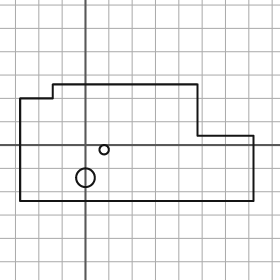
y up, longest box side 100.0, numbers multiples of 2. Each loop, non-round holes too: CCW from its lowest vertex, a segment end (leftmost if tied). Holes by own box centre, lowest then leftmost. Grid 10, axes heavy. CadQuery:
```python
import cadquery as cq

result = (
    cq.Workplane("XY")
    .moveTo(-28.0, -24.0)
    .lineTo(72.0, -24.0)
    .lineTo(72.0, 4.0)
    .lineTo(48.0, 4.0)
    .lineTo(48.0, 26.0)
    .lineTo(-14.0, 26.0)
    .lineTo(-14.0, 20.0)
    .lineTo(-28.0, 20.0)
    .close()
    .moveTo(0.0, -14.0)
    .circle(4.0)
    .moveTo(8.0, -2.0)
    .circle(2.0)
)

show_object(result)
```